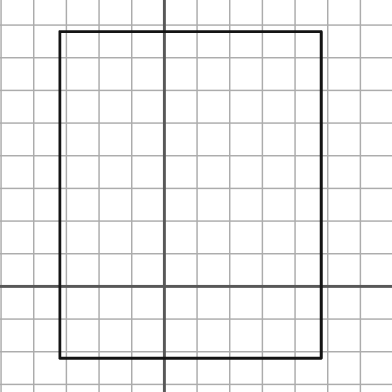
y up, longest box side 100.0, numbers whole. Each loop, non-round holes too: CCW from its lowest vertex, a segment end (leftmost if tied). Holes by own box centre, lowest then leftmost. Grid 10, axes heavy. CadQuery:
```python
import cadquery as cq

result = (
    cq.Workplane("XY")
    .moveTo(-32.0, -22.0)
    .lineTo(48.0, -22.0)
    .lineTo(48.0, 78.0)
    .lineTo(-32.0, 78.0)
    .close()
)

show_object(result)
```